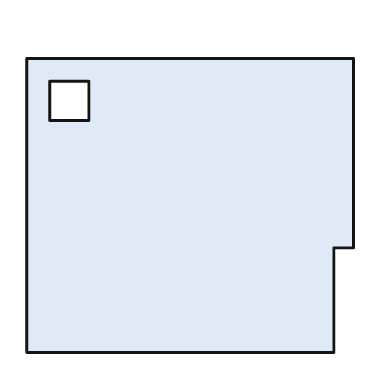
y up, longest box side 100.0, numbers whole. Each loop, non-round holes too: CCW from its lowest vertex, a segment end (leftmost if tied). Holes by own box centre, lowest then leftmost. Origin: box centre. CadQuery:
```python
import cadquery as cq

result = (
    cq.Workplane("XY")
    .moveTo(-50.0, -45.0)
    .lineTo(44.0, -45.0)
    .lineTo(44.0, -13.0)
    .lineTo(50.0, -13.0)
    .lineTo(50.0, 45.0)
    .lineTo(-50.0, 45.0)
    .close()
    .moveTo(-43.0, 26.0)
    .lineTo(-31.0, 26.0)
    .lineTo(-31.0, 38.0)
    .lineTo(-43.0, 38.0)
    .close()
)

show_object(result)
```